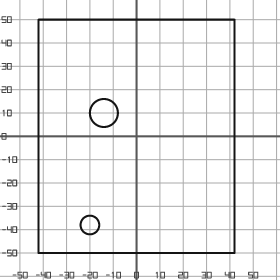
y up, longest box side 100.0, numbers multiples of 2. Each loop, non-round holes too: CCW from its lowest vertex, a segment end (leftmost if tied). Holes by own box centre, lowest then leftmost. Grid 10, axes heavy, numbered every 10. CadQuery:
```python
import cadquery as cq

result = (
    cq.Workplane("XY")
    .moveTo(-42.0, -50.0)
    .lineTo(42.0, -50.0)
    .lineTo(42.0, 50.0)
    .lineTo(-42.0, 50.0)
    .close()
    .moveTo(-20.0, -38.0)
    .circle(4.0)
    .moveTo(-14.0, 10.0)
    .circle(6.0)
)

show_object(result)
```